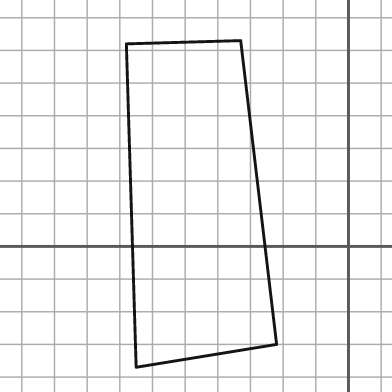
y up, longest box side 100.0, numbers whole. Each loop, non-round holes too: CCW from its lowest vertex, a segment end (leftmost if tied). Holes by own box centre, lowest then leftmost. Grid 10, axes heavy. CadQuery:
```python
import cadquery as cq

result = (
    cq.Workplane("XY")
    .moveTo(-65.0, -37.0)
    .lineTo(-22.0, -30.0)
    .lineTo(-33.0, 63.0)
    .lineTo(-68.0, 62.0)
    .close()
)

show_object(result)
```